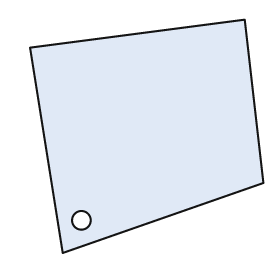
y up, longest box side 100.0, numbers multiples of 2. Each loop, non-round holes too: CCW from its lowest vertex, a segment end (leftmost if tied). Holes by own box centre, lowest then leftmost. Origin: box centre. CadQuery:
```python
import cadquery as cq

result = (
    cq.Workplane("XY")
    .moveTo(-36.0, -50.0)
    .lineTo(50.0, -20.0)
    .lineTo(42.0, 50.0)
    .lineTo(-50.0, 38.0)
    .close()
    .moveTo(-28.0, -36.0)
    .circle(4.0)
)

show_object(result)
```